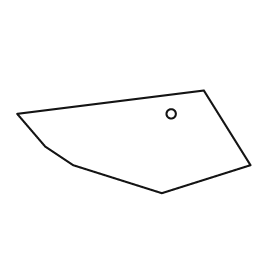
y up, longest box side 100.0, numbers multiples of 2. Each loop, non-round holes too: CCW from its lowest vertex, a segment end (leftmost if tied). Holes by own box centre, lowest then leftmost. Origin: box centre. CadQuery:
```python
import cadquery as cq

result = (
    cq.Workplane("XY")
    .moveTo(12.0, -22.0)
    .lineTo(50.0, -10.0)
    .lineTo(30.0, 22.0)
    .lineTo(-50.0, 12.0)
    .lineTo(-38.0, -2.0)
    .lineTo(-26.0, -10.0)
    .close()
    .moveTo(16.0, 12.0)
    .circle(2.0)
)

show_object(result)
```